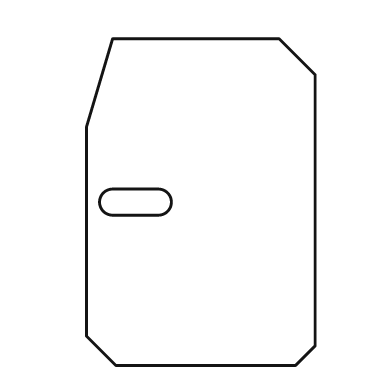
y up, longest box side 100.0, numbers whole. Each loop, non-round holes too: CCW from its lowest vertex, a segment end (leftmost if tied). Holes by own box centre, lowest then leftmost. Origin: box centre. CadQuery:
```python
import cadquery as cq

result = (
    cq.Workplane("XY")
    .moveTo(-26.0, -50.0)
    .lineTo(29.0, -50.0)
    .lineTo(35.0, -44.0)
    .lineTo(35.0, 39.0)
    .lineTo(24.0, 50.0)
    .lineTo(-27.0, 50.0)
    .lineTo(-35.0, 23.0)
    .lineTo(-35.0, -41.0)
    .close()
    .moveTo(-27.0, -4.0)
    .lineTo(-13.0, -4.0)
    .threePointArc((-9.0, 0.0), (-13.0, 4.0))
    .lineTo(-27.0, 4.0)
    .threePointArc((-31.0, 0.0), (-27.0, -4.0))
    .close()
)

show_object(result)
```